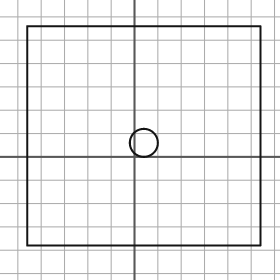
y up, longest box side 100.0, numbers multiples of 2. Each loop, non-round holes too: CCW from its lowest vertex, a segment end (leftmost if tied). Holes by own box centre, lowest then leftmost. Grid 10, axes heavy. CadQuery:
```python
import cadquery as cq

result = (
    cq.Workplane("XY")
    .moveTo(-46.0, -38.0)
    .lineTo(54.0, -38.0)
    .lineTo(54.0, 56.0)
    .lineTo(-46.0, 56.0)
    .close()
    .moveTo(4.0, 6.0)
    .circle(6.0)
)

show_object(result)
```